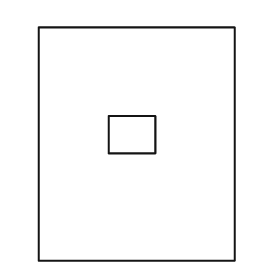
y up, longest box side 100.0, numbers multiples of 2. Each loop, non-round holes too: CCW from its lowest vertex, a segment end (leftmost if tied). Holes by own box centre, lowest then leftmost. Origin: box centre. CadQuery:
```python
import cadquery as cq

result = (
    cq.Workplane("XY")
    .moveTo(-42.0, -50.0)
    .lineTo(42.0, -50.0)
    .lineTo(42.0, 50.0)
    .lineTo(-42.0, 50.0)
    .close()
    .moveTo(-12.0, -4.0)
    .lineTo(8.0, -4.0)
    .lineTo(8.0, 12.0)
    .lineTo(-12.0, 12.0)
    .close()
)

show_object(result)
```